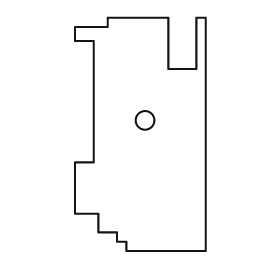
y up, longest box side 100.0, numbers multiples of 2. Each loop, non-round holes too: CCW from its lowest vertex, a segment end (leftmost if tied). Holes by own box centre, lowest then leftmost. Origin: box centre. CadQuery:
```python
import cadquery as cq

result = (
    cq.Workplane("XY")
    .moveTo(-6.0, -50.0)
    .lineTo(28.0, -50.0)
    .lineTo(28.0, 50.0)
    .lineTo(24.0, 50.0)
    .lineTo(24.0, 28.0)
    .lineTo(12.0, 28.0)
    .lineTo(12.0, 50.0)
    .lineTo(-14.0, 50.0)
    .lineTo(-14.0, 46.0)
    .lineTo(-28.0, 46.0)
    .lineTo(-28.0, 40.0)
    .lineTo(-20.0, 40.0)
    .lineTo(-20.0, -12.0)
    .lineTo(-28.0, -12.0)
    .lineTo(-28.0, -34.0)
    .lineTo(-18.0, -34.0)
    .lineTo(-18.0, -42.0)
    .lineTo(-10.0, -42.0)
    .lineTo(-10.0, -46.0)
    .lineTo(-6.0, -46.0)
    .close()
    .moveTo(2.0, 6.0)
    .circle(4.0)
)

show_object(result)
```